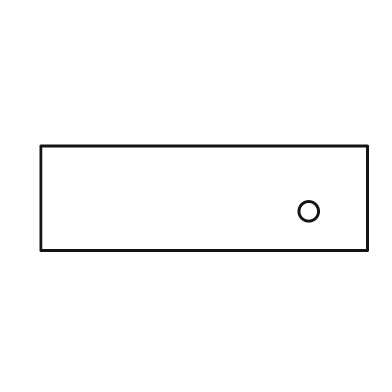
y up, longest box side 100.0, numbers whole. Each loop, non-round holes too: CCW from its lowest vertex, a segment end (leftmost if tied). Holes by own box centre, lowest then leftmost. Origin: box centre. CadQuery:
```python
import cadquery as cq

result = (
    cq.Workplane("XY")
    .moveTo(-50.0, -16.0)
    .lineTo(50.0, -16.0)
    .lineTo(50.0, 16.0)
    .lineTo(-50.0, 16.0)
    .close()
    .moveTo(32.0, -4.0)
    .circle(3.0)
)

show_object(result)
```